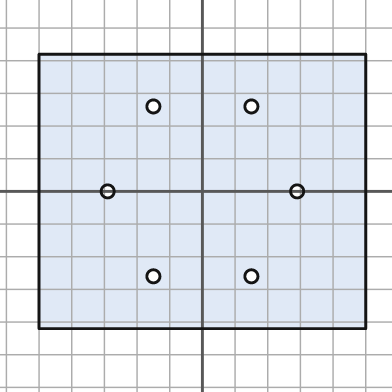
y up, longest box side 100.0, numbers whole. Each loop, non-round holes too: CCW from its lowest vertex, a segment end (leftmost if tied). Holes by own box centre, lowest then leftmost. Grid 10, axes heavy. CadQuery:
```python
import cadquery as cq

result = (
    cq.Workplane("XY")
    .moveTo(-50.0, -42.0)
    .lineTo(50.0, -42.0)
    .lineTo(50.0, 42.0)
    .lineTo(-50.0, 42.0)
    .close()
    .moveTo(-15.0, -26.0)
    .circle(2.0)
    .moveTo(15.0, -26.0)
    .circle(2.0)
    .moveTo(-29.0, 0.0)
    .circle(2.0)
    .moveTo(29.0, 0.0)
    .circle(2.0)
    .moveTo(-15.0, 26.0)
    .circle(2.0)
    .moveTo(15.0, 26.0)
    .circle(2.0)
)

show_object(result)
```